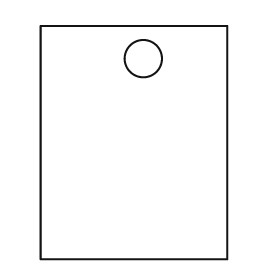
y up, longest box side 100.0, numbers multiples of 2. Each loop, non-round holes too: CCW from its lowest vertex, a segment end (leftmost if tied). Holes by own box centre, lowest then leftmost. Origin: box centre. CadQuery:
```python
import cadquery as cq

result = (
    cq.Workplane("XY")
    .moveTo(-40.0, -50.0)
    .lineTo(40.0, -50.0)
    .lineTo(40.0, 50.0)
    .lineTo(-40.0, 50.0)
    .close()
    .moveTo(4.0, 36.0)
    .circle(8.0)
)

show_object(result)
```